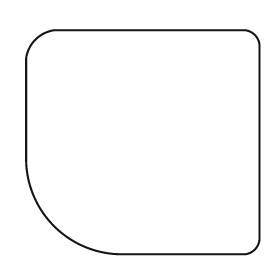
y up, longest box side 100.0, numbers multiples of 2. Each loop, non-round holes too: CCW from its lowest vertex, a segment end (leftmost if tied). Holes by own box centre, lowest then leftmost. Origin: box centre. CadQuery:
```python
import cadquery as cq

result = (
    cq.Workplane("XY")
    .moveTo(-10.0, -48.0)
    .lineTo(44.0, -48.0)
    .threePointArc((48.0, -46.0), (50.0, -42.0))
    .lineTo(50.0, 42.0)
    .threePointArc((48.0, 46.0), (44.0, 48.0))
    .lineTo(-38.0, 48.0)
    .threePointArc((-46.0, 44.0), (-50.0, 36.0))
    .lineTo(-50.0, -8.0)
    .threePointArc((-38.0, -36.0), (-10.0, -48.0))
    .close()
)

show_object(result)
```